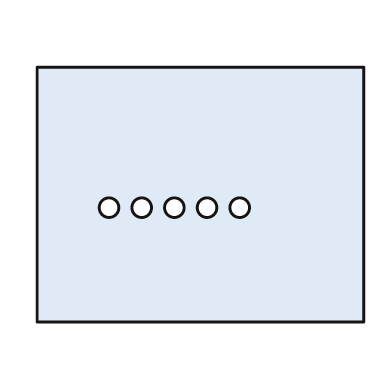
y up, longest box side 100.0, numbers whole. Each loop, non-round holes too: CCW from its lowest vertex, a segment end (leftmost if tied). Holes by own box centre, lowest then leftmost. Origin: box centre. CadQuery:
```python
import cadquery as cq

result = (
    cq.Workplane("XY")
    .moveTo(-50.0, -39.0)
    .lineTo(50.0, -39.0)
    .lineTo(50.0, 39.0)
    .lineTo(-50.0, 39.0)
    .close()
    .moveTo(-28.0, -4.0)
    .circle(3.0)
    .moveTo(-18.0, -4.0)
    .circle(3.0)
    .moveTo(-8.0, -4.0)
    .circle(3.0)
    .moveTo(2.0, -4.0)
    .circle(3.0)
    .moveTo(12.0, -4.0)
    .circle(3.0)
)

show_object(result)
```